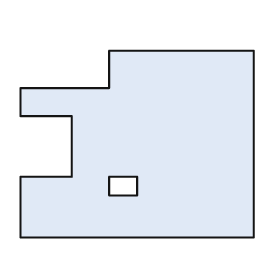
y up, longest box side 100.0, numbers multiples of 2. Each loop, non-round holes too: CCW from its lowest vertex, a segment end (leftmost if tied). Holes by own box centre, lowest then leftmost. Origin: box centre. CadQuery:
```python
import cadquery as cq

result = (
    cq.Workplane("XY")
    .moveTo(-50.0, -40.0)
    .lineTo(50.0, -40.0)
    .lineTo(50.0, 40.0)
    .lineTo(-12.0, 40.0)
    .lineTo(-12.0, 24.0)
    .lineTo(-50.0, 24.0)
    .lineTo(-50.0, 12.0)
    .lineTo(-28.0, 12.0)
    .lineTo(-28.0, -14.0)
    .lineTo(-50.0, -14.0)
    .close()
    .moveTo(-12.0, -22.0)
    .lineTo(0.0, -22.0)
    .lineTo(0.0, -14.0)
    .lineTo(-12.0, -14.0)
    .close()
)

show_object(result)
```